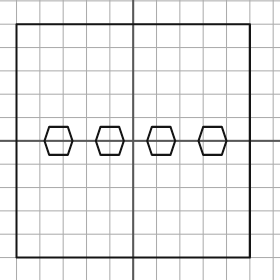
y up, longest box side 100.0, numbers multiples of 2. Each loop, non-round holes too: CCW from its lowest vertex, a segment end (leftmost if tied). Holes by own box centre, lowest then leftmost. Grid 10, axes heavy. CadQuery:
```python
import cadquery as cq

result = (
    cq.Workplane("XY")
    .moveTo(-50.0, -50.0)
    .lineTo(50.0, -50.0)
    .lineTo(50.0, 50.0)
    .lineTo(-50.0, 50.0)
    .close()
    .moveTo(-36.0, -6.0)
    .lineTo(-28.0, -6.0)
    .lineTo(-26.0, 0.0)
    .lineTo(-28.0, 6.0)
    .lineTo(-36.0, 6.0)
    .lineTo(-38.0, 0.0)
    .close()
    .moveTo(-14.0, -6.0)
    .lineTo(-6.0, -6.0)
    .lineTo(-4.0, 0.0)
    .lineTo(-6.0, 6.0)
    .lineTo(-14.0, 6.0)
    .lineTo(-16.0, 0.0)
    .close()
    .moveTo(8.0, -6.0)
    .lineTo(16.0, -6.0)
    .lineTo(18.0, 0.0)
    .lineTo(16.0, 6.0)
    .lineTo(8.0, 6.0)
    .lineTo(6.0, 0.0)
    .close()
    .moveTo(30.0, -6.0)
    .lineTo(38.0, -6.0)
    .lineTo(40.0, 0.0)
    .lineTo(38.0, 6.0)
    .lineTo(30.0, 6.0)
    .lineTo(28.0, 0.0)
    .close()
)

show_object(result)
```